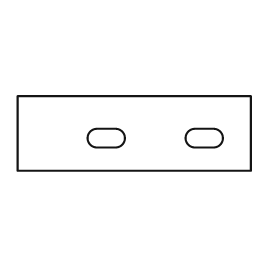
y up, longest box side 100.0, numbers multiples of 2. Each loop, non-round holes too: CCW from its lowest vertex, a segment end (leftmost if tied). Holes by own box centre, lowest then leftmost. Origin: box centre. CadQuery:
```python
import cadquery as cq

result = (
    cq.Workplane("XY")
    .moveTo(-50.0, -16.0)
    .lineTo(50.0, -16.0)
    .lineTo(50.0, 16.0)
    .lineTo(-50.0, 16.0)
    .close()
    .moveTo(-16.0, -6.0)
    .lineTo(-8.0, -6.0)
    .threePointArc((-4.0, -2.0), (-8.0, 2.0))
    .lineTo(-16.0, 2.0)
    .threePointArc((-20.0, -2.0), (-16.0, -6.0))
    .close()
    .moveTo(26.0, -6.0)
    .lineTo(34.0, -6.0)
    .threePointArc((38.0, -2.0), (34.0, 2.0))
    .lineTo(26.0, 2.0)
    .threePointArc((22.0, -2.0), (26.0, -6.0))
    .close()
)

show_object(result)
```